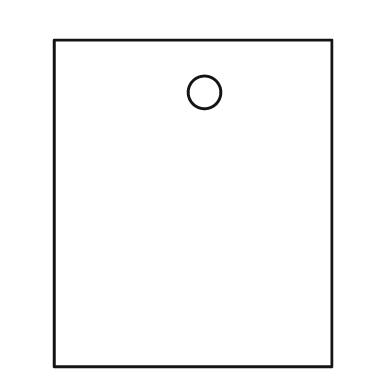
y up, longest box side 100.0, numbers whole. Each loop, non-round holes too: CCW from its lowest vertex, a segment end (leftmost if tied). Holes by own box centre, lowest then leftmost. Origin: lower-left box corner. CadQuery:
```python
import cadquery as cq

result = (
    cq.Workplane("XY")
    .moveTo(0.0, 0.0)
    .lineTo(85.0, 0.0)
    .lineTo(85.0, 100.0)
    .lineTo(0.0, 100.0)
    .close()
    .moveTo(46.0, 84.0)
    .circle(5.0)
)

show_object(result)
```